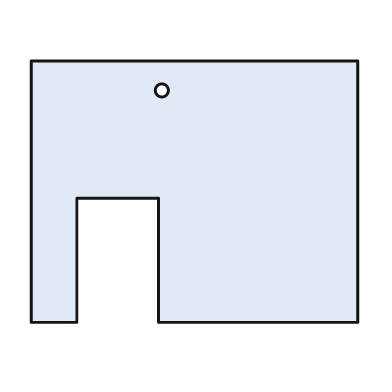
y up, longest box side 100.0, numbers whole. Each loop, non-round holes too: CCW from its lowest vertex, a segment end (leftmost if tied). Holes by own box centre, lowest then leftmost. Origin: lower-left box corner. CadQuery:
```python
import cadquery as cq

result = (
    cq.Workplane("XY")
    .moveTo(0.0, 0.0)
    .lineTo(14.0, 0.0)
    .lineTo(14.0, 38.0)
    .lineTo(39.0, 38.0)
    .lineTo(39.0, 0.0)
    .lineTo(100.0, 0.0)
    .lineTo(100.0, 80.0)
    .lineTo(0.0, 80.0)
    .close()
    .moveTo(40.0, 71.0)
    .circle(2.0)
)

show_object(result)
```